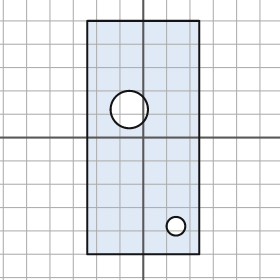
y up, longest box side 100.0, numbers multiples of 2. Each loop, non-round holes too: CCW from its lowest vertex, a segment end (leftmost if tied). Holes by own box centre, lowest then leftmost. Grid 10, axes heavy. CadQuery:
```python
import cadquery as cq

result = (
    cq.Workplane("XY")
    .moveTo(-24.0, -50.0)
    .lineTo(24.0, -50.0)
    .lineTo(24.0, 50.0)
    .lineTo(-24.0, 50.0)
    .close()
    .moveTo(14.0, -38.0)
    .circle(4.0)
    .moveTo(-6.0, 12.0)
    .circle(8.0)
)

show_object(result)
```